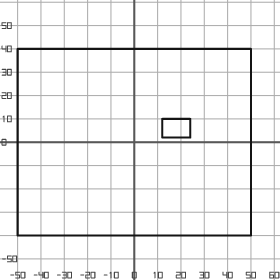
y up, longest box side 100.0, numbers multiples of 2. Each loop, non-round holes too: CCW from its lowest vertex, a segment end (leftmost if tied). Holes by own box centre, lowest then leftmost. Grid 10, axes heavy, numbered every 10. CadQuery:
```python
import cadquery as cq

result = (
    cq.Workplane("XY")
    .moveTo(-50.0, -40.0)
    .lineTo(50.0, -40.0)
    .lineTo(50.0, 40.0)
    .lineTo(-50.0, 40.0)
    .close()
    .moveTo(12.0, 2.0)
    .lineTo(24.0, 2.0)
    .lineTo(24.0, 10.0)
    .lineTo(12.0, 10.0)
    .close()
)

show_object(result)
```